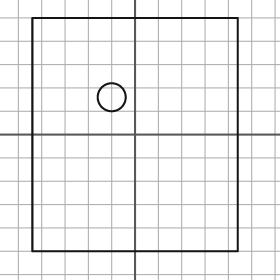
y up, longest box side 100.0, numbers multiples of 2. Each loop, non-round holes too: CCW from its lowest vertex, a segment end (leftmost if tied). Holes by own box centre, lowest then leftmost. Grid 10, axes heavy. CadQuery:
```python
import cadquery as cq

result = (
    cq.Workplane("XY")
    .moveTo(-44.0, -50.0)
    .lineTo(44.0, -50.0)
    .lineTo(44.0, 50.0)
    .lineTo(-44.0, 50.0)
    .close()
    .moveTo(-10.0, 16.0)
    .circle(6.0)
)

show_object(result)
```